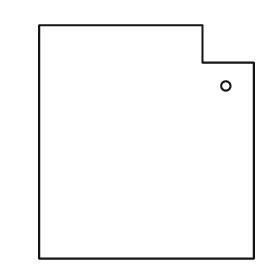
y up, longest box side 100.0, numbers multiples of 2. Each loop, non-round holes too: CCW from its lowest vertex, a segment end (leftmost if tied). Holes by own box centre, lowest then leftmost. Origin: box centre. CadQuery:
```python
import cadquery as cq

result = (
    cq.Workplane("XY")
    .moveTo(-46.0, -50.0)
    .lineTo(46.0, -50.0)
    .lineTo(46.0, 34.0)
    .lineTo(24.0, 34.0)
    .lineTo(24.0, 50.0)
    .lineTo(-46.0, 50.0)
    .close()
    .moveTo(34.0, 24.0)
    .circle(2.0)
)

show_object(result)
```